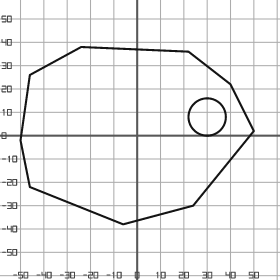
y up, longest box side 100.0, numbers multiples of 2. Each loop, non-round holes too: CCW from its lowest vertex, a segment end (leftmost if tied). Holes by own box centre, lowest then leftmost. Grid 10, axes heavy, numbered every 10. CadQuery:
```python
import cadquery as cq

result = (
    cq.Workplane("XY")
    .moveTo(-6.0, -38.0)
    .lineTo(24.0, -30.0)
    .lineTo(50.0, 2.0)
    .lineTo(40.0, 22.0)
    .lineTo(22.0, 36.0)
    .lineTo(-24.0, 38.0)
    .lineTo(-46.0, 26.0)
    .lineTo(-50.0, -2.0)
    .lineTo(-46.0, -22.0)
    .close()
    .moveTo(30.0, 8.0)
    .circle(8.0)
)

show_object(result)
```